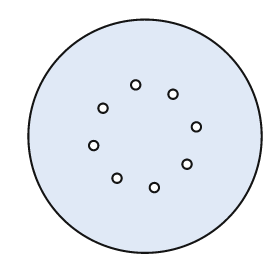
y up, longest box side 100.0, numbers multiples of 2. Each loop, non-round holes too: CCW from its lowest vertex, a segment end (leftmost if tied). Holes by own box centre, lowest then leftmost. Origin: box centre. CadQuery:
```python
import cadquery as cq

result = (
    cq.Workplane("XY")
    .moveTo(0.0, 0.0)
    .circle(50.0)
    .moveTo(4.0, -22.0)
    .circle(2.0)
    .moveTo(-12.0, -18.0)
    .circle(2.0)
    .moveTo(18.0, -12.0)
    .circle(2.0)
    .moveTo(-22.0, -4.0)
    .circle(2.0)
    .moveTo(22.0, 4.0)
    .circle(2.0)
    .moveTo(-18.0, 12.0)
    .circle(2.0)
    .moveTo(12.0, 18.0)
    .circle(2.0)
    .moveTo(-4.0, 22.0)
    .circle(2.0)
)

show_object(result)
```